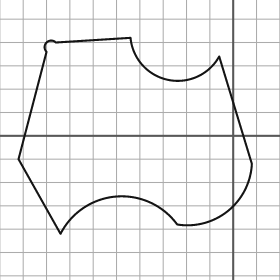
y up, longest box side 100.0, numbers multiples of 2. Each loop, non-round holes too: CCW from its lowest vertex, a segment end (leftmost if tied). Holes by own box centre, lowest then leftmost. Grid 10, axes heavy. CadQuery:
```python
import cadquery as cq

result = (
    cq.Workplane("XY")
    .moveTo(-74.0, -42.0)
    .threePointArc((-50.0, -26.0), (-24.0, -38.0))
    .threePointArc((-2.0, -32.0), (8.0, -12.0))
    .lineTo(-6.0, 34.0)
    .threePointArc((-28.0, 24.0), (-44.0, 42.0))
    .lineTo(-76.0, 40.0)
    .threePointArc((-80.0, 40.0), (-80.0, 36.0))
    .lineTo(-92.0, -10.0)
    .close()
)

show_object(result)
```